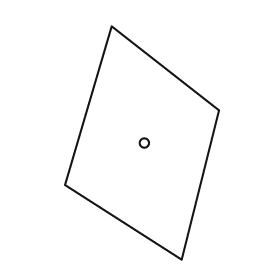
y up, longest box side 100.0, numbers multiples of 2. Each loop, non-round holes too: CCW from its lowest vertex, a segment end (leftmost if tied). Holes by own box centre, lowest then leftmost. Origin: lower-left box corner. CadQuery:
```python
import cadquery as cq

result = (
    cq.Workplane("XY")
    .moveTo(50.0, 0.0)
    .lineTo(66.0, 64.0)
    .lineTo(20.0, 100.0)
    .lineTo(0.0, 32.0)
    .close()
    .moveTo(34.0, 50.0)
    .circle(2.0)
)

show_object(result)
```